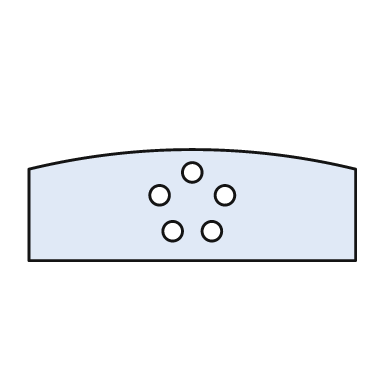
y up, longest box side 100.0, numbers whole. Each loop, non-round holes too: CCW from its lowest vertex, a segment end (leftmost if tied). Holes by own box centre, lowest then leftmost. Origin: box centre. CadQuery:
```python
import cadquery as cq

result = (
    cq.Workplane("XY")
    .moveTo(-50.0, -17.0)
    .lineTo(50.0, -17.0)
    .lineTo(50.0, 11.0)
    .threePointArc((0.0, 17.0), (-50.0, 11.0))
    .close()
    .moveTo(-6.0, -8.0)
    .circle(3.0)
    .moveTo(6.0, -8.0)
    .circle(3.0)
    .moveTo(-10.0, 3.0)
    .circle(3.0)
    .moveTo(10.0, 3.0)
    .circle(3.0)
    .moveTo(0.0, 10.0)
    .circle(3.0)
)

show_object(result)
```